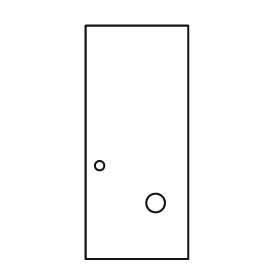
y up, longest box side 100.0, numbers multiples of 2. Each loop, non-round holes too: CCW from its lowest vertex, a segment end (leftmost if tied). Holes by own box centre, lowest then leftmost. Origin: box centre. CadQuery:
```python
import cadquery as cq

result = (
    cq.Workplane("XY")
    .moveTo(-22.0, -50.0)
    .lineTo(22.0, -50.0)
    .lineTo(22.0, 50.0)
    .lineTo(-22.0, 50.0)
    .close()
    .moveTo(8.0, -26.0)
    .circle(4.0)
    .moveTo(-16.0, -10.0)
    .circle(2.0)
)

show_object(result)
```